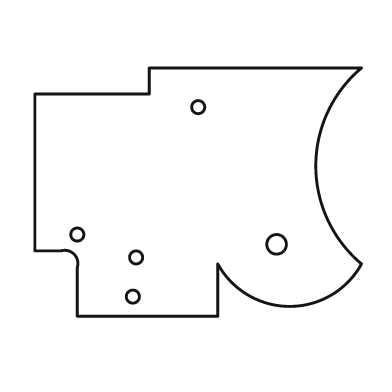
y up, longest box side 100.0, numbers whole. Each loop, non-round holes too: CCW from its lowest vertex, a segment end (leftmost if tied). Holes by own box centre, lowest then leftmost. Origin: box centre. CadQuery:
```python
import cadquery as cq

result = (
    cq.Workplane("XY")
    .moveTo(-37.0, -38.0)
    .lineTo(6.0, -38.0)
    .lineTo(6.0, -22.0)
    .threePointArc((28.0, -35.0), (50.0, -22.0))
    .threePointArc((36.0, 8.0), (50.0, 38.0))
    .lineTo(-15.0, 38.0)
    .lineTo(-15.0, 30.0)
    .lineTo(-50.0, 30.0)
    .lineTo(-50.0, -18.0)
    .lineTo(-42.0, -18.0)
    .threePointArc((-38.0, -19.0), (-37.0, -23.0))
    .close()
    .moveTo(-20.0, -32.0)
    .circle(2.0)
    .moveTo(-19.0, -20.0)
    .circle(2.0)
    .moveTo(24.0, -16.0)
    .circle(3.0)
    .moveTo(-37.0, -13.0)
    .circle(2.0)
    .moveTo(0.0, 26.0)
    .circle(2.0)
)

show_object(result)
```